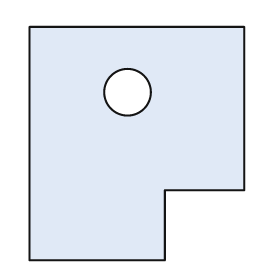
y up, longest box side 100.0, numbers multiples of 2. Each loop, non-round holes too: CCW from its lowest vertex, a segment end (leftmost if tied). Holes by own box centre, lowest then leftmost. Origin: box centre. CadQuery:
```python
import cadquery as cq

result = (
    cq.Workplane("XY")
    .moveTo(-46.0, -50.0)
    .lineTo(12.0, -50.0)
    .lineTo(12.0, -20.0)
    .lineTo(46.0, -20.0)
    .lineTo(46.0, 50.0)
    .lineTo(-46.0, 50.0)
    .close()
    .moveTo(-4.0, 22.0)
    .circle(10.0)
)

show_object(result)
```